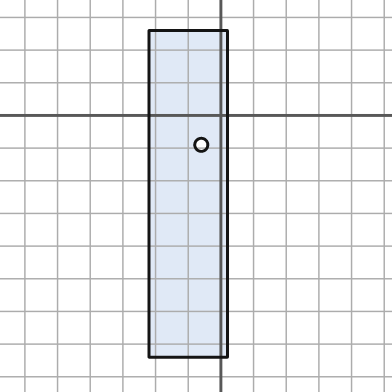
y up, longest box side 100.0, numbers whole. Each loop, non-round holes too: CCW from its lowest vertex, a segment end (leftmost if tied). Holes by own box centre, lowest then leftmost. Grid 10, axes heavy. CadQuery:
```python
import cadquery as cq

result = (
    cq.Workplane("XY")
    .moveTo(-22.0, -74.0)
    .lineTo(2.0, -74.0)
    .lineTo(2.0, 26.0)
    .lineTo(-22.0, 26.0)
    .close()
    .moveTo(-6.0, -9.0)
    .circle(2.0)
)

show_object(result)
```